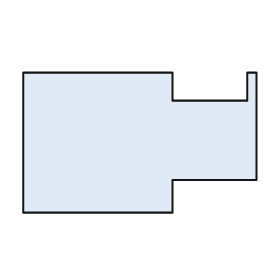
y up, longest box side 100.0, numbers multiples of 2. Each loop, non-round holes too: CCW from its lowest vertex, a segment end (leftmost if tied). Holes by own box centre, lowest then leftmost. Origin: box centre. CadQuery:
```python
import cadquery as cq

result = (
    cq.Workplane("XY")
    .moveTo(-50.0, -30.0)
    .lineTo(14.0, -30.0)
    .lineTo(14.0, -16.0)
    .lineTo(50.0, -16.0)
    .lineTo(50.0, 30.0)
    .lineTo(46.0, 30.0)
    .lineTo(46.0, 18.0)
    .lineTo(14.0, 18.0)
    .lineTo(14.0, 30.0)
    .lineTo(-50.0, 30.0)
    .close()
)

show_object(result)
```